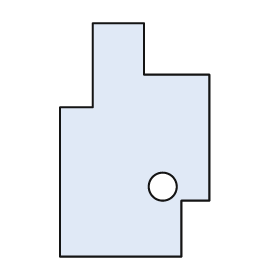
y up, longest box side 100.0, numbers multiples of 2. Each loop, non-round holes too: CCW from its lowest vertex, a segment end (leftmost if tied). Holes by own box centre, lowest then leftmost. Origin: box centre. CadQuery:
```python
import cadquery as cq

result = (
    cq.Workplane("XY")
    .moveTo(-32.0, -50.0)
    .lineTo(20.0, -50.0)
    .lineTo(20.0, -26.0)
    .lineTo(32.0, -26.0)
    .lineTo(32.0, 28.0)
    .lineTo(4.0, 28.0)
    .lineTo(4.0, 50.0)
    .lineTo(-18.0, 50.0)
    .lineTo(-18.0, 14.0)
    .lineTo(-32.0, 14.0)
    .close()
    .moveTo(12.0, -20.0)
    .circle(6.0)
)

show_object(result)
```